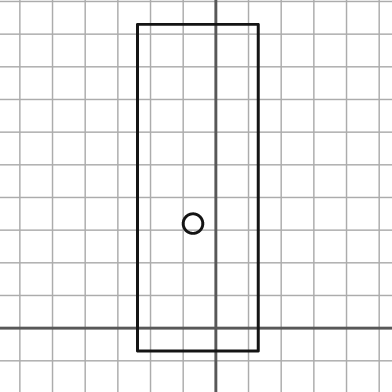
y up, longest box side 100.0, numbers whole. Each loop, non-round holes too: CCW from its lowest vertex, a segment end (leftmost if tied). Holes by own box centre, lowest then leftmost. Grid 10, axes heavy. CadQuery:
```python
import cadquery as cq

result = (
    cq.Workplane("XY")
    .moveTo(-24.0, -7.0)
    .lineTo(13.0, -7.0)
    .lineTo(13.0, 93.0)
    .lineTo(-24.0, 93.0)
    .close()
    .moveTo(-7.0, 32.0)
    .circle(3.0)
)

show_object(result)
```